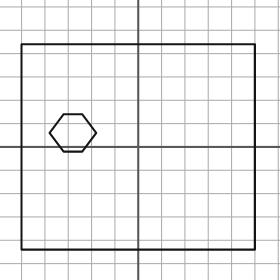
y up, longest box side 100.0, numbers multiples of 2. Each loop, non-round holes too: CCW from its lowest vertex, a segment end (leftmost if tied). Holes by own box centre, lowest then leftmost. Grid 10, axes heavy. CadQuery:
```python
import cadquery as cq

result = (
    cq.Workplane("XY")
    .moveTo(-50.0, -44.0)
    .lineTo(50.0, -44.0)
    .lineTo(50.0, 44.0)
    .lineTo(-50.0, 44.0)
    .close()
    .moveTo(-32.0, -2.0)
    .lineTo(-24.0, -2.0)
    .lineTo(-18.0, 6.0)
    .lineTo(-24.0, 14.0)
    .lineTo(-32.0, 14.0)
    .lineTo(-38.0, 6.0)
    .close()
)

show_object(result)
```